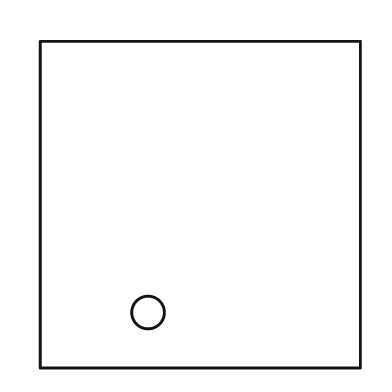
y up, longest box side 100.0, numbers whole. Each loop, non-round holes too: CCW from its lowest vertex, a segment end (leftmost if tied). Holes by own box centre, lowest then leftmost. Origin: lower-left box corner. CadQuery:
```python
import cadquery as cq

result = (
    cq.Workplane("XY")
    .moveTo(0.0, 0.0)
    .lineTo(98.0, 0.0)
    .lineTo(98.0, 100.0)
    .lineTo(0.0, 100.0)
    .close()
    .moveTo(33.0, 17.0)
    .circle(5.0)
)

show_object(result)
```